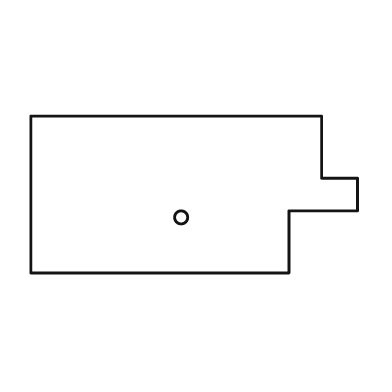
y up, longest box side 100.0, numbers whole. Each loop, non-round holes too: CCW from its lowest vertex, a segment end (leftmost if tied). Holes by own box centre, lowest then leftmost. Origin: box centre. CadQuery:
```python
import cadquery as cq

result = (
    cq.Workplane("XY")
    .moveTo(-50.0, -24.0)
    .lineTo(29.0, -24.0)
    .lineTo(29.0, -5.0)
    .lineTo(50.0, -5.0)
    .lineTo(50.0, 5.0)
    .lineTo(39.0, 5.0)
    .lineTo(39.0, 24.0)
    .lineTo(-50.0, 24.0)
    .close()
    .moveTo(-4.0, -7.0)
    .circle(2.0)
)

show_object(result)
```